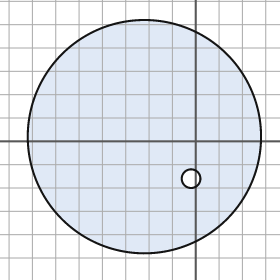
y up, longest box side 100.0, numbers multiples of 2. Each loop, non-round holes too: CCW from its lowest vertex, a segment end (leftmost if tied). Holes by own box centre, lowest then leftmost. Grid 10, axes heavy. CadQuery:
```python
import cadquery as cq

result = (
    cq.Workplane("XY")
    .moveTo(-22.0, 2.0)
    .circle(50.0)
    .moveTo(-2.0, -16.0)
    .circle(4.0)
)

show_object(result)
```